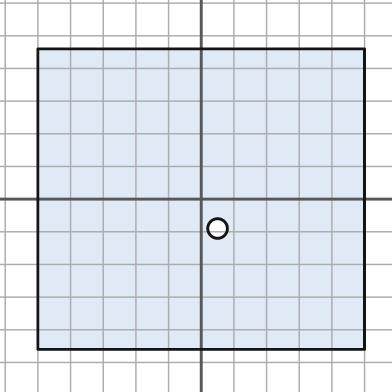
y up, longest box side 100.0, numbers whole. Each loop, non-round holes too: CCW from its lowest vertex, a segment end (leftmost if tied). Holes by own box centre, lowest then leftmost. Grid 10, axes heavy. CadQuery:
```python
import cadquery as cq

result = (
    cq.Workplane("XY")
    .moveTo(-50.0, -46.0)
    .lineTo(50.0, -46.0)
    .lineTo(50.0, 46.0)
    .lineTo(-50.0, 46.0)
    .close()
    .moveTo(5.0, -9.0)
    .circle(3.0)
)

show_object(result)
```